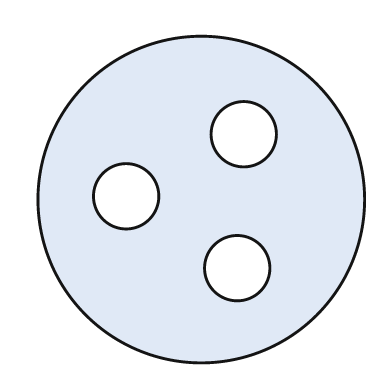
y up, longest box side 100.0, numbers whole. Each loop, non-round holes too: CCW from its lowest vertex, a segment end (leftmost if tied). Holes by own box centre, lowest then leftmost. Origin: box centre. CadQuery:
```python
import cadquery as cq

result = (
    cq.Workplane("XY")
    .moveTo(0.0, 0.0)
    .circle(50.0)
    .moveTo(11.0, -21.0)
    .circle(10.0)
    .moveTo(-23.0, 1.0)
    .circle(10.0)
    .moveTo(13.0, 20.0)
    .circle(10.0)
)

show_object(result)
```